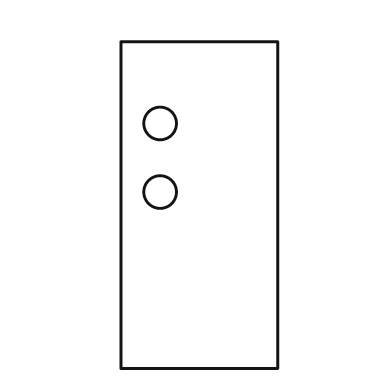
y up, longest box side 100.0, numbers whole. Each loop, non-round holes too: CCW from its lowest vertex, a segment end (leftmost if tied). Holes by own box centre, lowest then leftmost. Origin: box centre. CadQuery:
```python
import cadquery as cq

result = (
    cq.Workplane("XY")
    .moveTo(-24.0, -50.0)
    .lineTo(24.0, -50.0)
    .lineTo(24.0, 50.0)
    .lineTo(-24.0, 50.0)
    .close()
    .moveTo(-12.0, 4.0)
    .circle(5.0)
    .moveTo(-12.0, 25.0)
    .circle(5.0)
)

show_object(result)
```